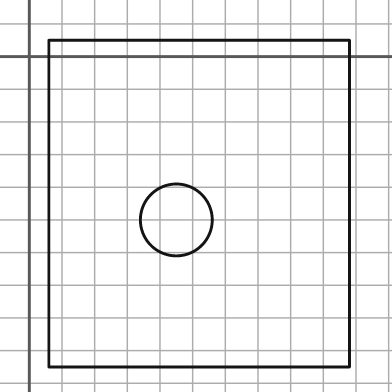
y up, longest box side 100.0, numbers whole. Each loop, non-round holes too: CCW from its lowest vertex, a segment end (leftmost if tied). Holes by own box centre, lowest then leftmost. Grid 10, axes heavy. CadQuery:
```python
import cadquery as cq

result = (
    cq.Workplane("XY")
    .moveTo(6.0, -95.0)
    .lineTo(98.0, -95.0)
    .lineTo(98.0, 5.0)
    .lineTo(6.0, 5.0)
    .close()
    .moveTo(45.0, -50.0)
    .circle(11.0)
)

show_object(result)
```